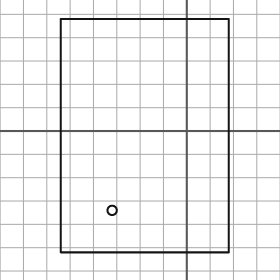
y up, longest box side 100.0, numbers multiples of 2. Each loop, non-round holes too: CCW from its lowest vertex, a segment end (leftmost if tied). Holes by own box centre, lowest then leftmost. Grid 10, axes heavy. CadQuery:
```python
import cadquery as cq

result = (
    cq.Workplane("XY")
    .moveTo(-54.0, -52.0)
    .lineTo(18.0, -52.0)
    .lineTo(18.0, 48.0)
    .lineTo(-54.0, 48.0)
    .close()
    .moveTo(-32.0, -34.0)
    .circle(2.0)
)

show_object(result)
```